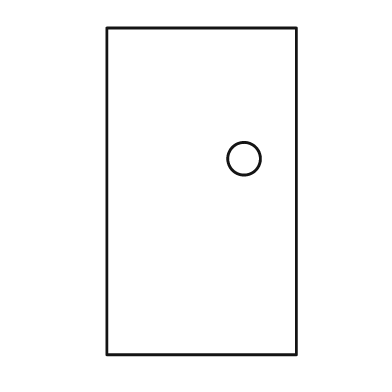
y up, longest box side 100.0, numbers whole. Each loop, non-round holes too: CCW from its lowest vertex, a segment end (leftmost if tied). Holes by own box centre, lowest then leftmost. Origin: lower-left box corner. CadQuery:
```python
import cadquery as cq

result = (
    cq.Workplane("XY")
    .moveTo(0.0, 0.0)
    .lineTo(58.0, 0.0)
    .lineTo(58.0, 100.0)
    .lineTo(0.0, 100.0)
    .close()
    .moveTo(42.0, 60.0)
    .circle(5.0)
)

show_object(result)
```